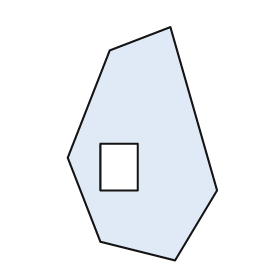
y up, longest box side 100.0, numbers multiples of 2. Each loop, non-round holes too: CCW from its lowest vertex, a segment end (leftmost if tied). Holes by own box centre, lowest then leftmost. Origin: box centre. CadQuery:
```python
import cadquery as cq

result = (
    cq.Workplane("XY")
    .moveTo(14.0, -50.0)
    .lineTo(32.0, -20.0)
    .lineTo(12.0, 50.0)
    .lineTo(-14.0, 40.0)
    .lineTo(-32.0, -6.0)
    .lineTo(-18.0, -42.0)
    .close()
    .moveTo(-18.0, -20.0)
    .lineTo(-2.0, -20.0)
    .lineTo(-2.0, 0.0)
    .lineTo(-18.0, 0.0)
    .close()
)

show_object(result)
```